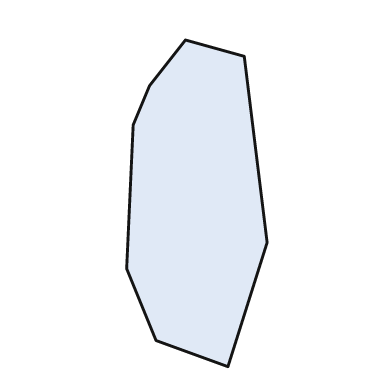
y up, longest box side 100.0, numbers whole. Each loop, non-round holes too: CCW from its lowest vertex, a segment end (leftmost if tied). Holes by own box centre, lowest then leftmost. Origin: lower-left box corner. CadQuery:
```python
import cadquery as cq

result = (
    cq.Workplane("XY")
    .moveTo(31.0, 0.0)
    .lineTo(43.0, 38.0)
    .lineTo(36.0, 95.0)
    .lineTo(18.0, 100.0)
    .lineTo(7.0, 86.0)
    .lineTo(2.0, 74.0)
    .lineTo(0.0, 30.0)
    .lineTo(9.0, 8.0)
    .close()
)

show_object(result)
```